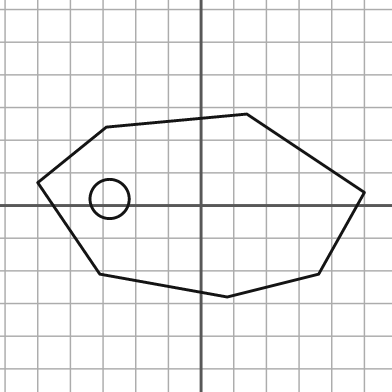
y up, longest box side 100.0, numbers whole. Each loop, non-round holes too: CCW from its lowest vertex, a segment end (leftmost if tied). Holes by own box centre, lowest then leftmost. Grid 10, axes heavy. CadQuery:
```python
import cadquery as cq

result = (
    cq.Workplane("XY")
    .moveTo(8.0, -28.0)
    .lineTo(36.0, -21.0)
    .lineTo(50.0, 4.0)
    .lineTo(14.0, 28.0)
    .lineTo(-29.0, 24.0)
    .lineTo(-50.0, 7.0)
    .lineTo(-31.0, -21.0)
    .close()
    .moveTo(-28.0, 2.0)
    .circle(6.0)
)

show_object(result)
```